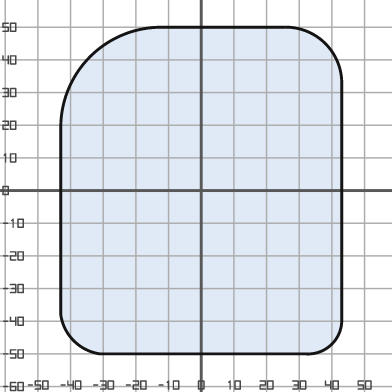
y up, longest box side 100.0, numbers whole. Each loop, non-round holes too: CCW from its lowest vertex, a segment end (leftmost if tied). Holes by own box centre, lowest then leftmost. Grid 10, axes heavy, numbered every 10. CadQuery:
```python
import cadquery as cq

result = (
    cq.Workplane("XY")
    .moveTo(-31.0, -50.0)
    .lineTo(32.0, -50.0)
    .threePointArc((40.0, -47.0), (43.0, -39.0))
    .lineTo(43.0, 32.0)
    .threePointArc((38.0, 45.0), (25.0, 50.0))
    .lineTo(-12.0, 50.0)
    .threePointArc((-34.0, 41.0), (-43.0, 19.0))
    .lineTo(-43.0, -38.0)
    .threePointArc((-39.0, -46.0), (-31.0, -50.0))
    .close()
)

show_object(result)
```